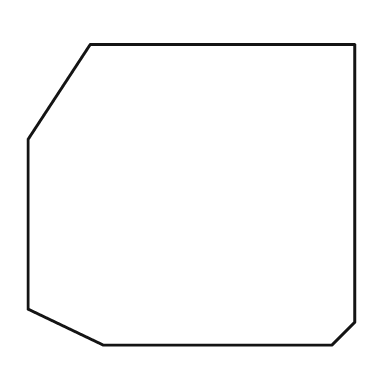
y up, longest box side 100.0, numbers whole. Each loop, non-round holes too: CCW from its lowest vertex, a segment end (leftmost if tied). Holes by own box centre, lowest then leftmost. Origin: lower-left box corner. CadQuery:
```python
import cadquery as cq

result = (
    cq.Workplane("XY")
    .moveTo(23.0, 0.0)
    .lineTo(93.0, 0.0)
    .lineTo(100.0, 7.0)
    .lineTo(100.0, 92.0)
    .lineTo(19.0, 92.0)
    .lineTo(0.0, 63.0)
    .lineTo(0.0, 11.0)
    .close()
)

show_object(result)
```